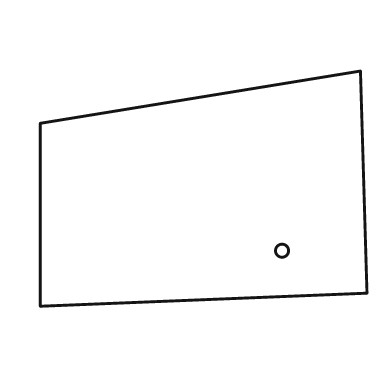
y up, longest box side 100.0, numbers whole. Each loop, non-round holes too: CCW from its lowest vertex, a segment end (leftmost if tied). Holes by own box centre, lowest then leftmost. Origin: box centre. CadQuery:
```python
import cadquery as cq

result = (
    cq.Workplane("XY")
    .moveTo(-50.0, -36.0)
    .lineTo(50.0, -32.0)
    .lineTo(48.0, 36.0)
    .lineTo(-50.0, 20.0)
    .close()
    .moveTo(24.0, -19.0)
    .circle(2.0)
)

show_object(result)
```